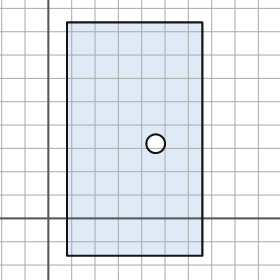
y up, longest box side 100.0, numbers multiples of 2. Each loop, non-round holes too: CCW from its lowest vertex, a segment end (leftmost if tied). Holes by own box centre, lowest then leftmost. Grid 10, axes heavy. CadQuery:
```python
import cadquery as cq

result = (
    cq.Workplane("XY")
    .moveTo(8.0, -16.0)
    .lineTo(66.0, -16.0)
    .lineTo(66.0, 84.0)
    .lineTo(8.0, 84.0)
    .close()
    .moveTo(46.0, 32.0)
    .circle(4.0)
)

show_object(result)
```